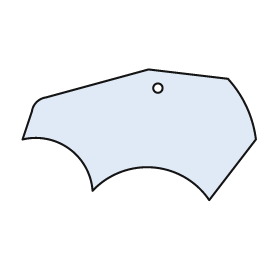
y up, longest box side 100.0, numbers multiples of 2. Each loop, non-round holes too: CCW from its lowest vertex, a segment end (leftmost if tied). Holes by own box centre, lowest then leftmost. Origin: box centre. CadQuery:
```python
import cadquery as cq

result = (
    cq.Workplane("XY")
    .moveTo(30.0, -28.0)
    .lineTo(50.0, -2.0)
    .threePointArc((46.0, 12.0), (38.0, 24.0))
    .lineTo(4.0, 28.0)
    .lineTo(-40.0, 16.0)
    .threePointArc((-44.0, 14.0), (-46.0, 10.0))
    .lineTo(-50.0, -2.0)
    .threePointArc((-30.0, -6.0), (-20.0, -24.0))
    .threePointArc((6.0, -14.0), (30.0, -28.0))
    .close()
    .moveTo(8.0, 20.0)
    .circle(2.0)
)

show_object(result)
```